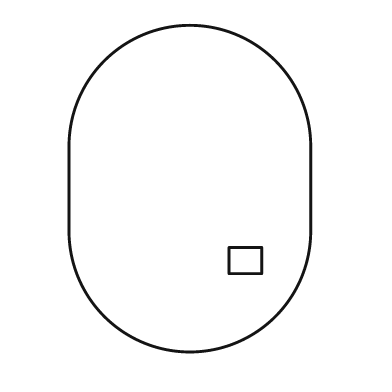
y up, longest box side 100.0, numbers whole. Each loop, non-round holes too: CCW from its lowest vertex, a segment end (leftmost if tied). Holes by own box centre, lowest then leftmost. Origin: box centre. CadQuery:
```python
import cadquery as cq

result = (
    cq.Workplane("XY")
    .moveTo(-37.0, -13.0)
    .threePointArc((0.0, -50.0), (37.0, -13.0))
    .lineTo(37.0, 13.0)
    .threePointArc((0.0, 50.0), (-37.0, 13.0))
    .close()
    .moveTo(12.0, -26.0)
    .lineTo(22.0, -26.0)
    .lineTo(22.0, -18.0)
    .lineTo(12.0, -18.0)
    .close()
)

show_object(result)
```